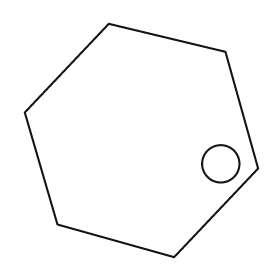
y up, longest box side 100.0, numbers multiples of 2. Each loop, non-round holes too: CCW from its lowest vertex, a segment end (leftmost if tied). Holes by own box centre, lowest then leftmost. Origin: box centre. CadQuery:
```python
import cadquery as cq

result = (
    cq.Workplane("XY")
    .moveTo(14.0, -50.0)
    .lineTo(50.0, -12.0)
    .lineTo(36.0, 38.0)
    .lineTo(-14.0, 50.0)
    .lineTo(-50.0, 12.0)
    .lineTo(-36.0, -36.0)
    .close()
    .moveTo(34.0, -10.0)
    .circle(8.0)
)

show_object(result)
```